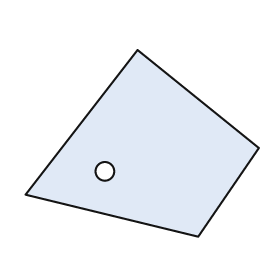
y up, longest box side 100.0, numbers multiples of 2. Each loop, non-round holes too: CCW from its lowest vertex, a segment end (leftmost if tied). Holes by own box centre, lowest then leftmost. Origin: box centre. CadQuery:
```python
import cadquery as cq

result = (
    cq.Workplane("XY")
    .moveTo(24.0, -40.0)
    .lineTo(50.0, -2.0)
    .lineTo(-2.0, 40.0)
    .lineTo(-50.0, -22.0)
    .close()
    .moveTo(-16.0, -12.0)
    .circle(4.0)
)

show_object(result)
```